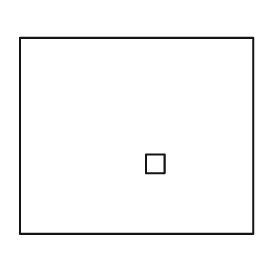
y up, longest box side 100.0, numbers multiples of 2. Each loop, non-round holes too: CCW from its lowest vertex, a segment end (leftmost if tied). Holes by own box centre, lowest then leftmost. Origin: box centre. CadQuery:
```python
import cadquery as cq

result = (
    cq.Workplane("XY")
    .moveTo(-50.0, -42.0)
    .lineTo(50.0, -42.0)
    .lineTo(50.0, 42.0)
    .lineTo(-50.0, 42.0)
    .close()
    .moveTo(4.0, -16.0)
    .lineTo(12.0, -16.0)
    .lineTo(12.0, -8.0)
    .lineTo(4.0, -8.0)
    .close()
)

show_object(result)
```